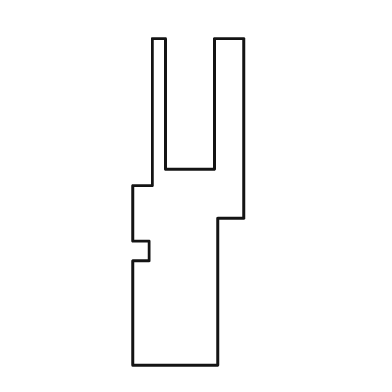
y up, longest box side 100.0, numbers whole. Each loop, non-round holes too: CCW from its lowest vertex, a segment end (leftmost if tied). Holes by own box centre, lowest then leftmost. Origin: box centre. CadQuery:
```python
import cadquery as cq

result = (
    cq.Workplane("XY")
    .moveTo(-17.0, -50.0)
    .lineTo(9.0, -50.0)
    .lineTo(9.0, -5.0)
    .lineTo(17.0, -5.0)
    .lineTo(17.0, 50.0)
    .lineTo(8.0, 50.0)
    .lineTo(8.0, 10.0)
    .lineTo(-7.0, 10.0)
    .lineTo(-7.0, 50.0)
    .lineTo(-11.0, 50.0)
    .lineTo(-11.0, 5.0)
    .lineTo(-17.0, 5.0)
    .lineTo(-17.0, -12.0)
    .lineTo(-12.0, -12.0)
    .lineTo(-12.0, -18.0)
    .lineTo(-17.0, -18.0)
    .close()
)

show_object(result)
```